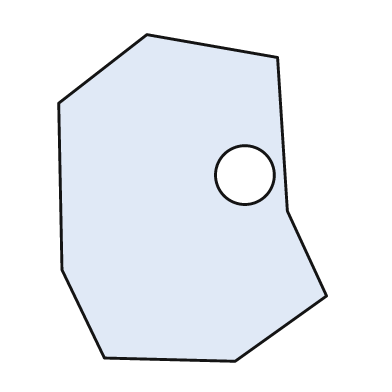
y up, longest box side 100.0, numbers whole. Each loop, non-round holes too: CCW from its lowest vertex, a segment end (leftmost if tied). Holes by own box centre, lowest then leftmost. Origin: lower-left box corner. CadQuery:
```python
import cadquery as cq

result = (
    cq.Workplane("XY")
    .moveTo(54.0, 0.0)
    .lineTo(82.0, 20.0)
    .lineTo(70.0, 46.0)
    .lineTo(67.0, 93.0)
    .lineTo(27.0, 100.0)
    .lineTo(0.0, 79.0)
    .lineTo(1.0, 28.0)
    .lineTo(14.0, 1.0)
    .close()
    .moveTo(57.0, 57.0)
    .circle(9.0)
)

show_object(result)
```